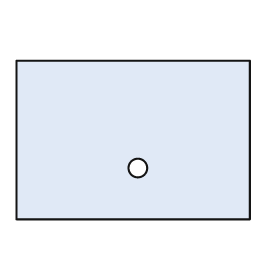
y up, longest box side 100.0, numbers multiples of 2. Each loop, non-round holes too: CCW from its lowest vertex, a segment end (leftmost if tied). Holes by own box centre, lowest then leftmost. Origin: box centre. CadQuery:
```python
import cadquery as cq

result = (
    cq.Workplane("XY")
    .moveTo(-50.0, -34.0)
    .lineTo(50.0, -34.0)
    .lineTo(50.0, 34.0)
    .lineTo(-50.0, 34.0)
    .close()
    .moveTo(2.0, -12.0)
    .circle(4.0)
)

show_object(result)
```